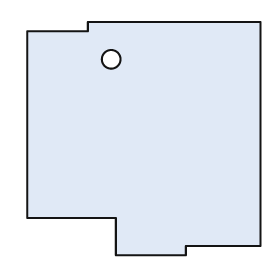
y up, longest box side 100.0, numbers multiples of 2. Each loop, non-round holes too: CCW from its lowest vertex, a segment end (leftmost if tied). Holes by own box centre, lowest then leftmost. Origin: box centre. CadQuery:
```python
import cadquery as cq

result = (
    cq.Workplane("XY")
    .moveTo(-12.0, -50.0)
    .lineTo(18.0, -50.0)
    .lineTo(18.0, -46.0)
    .lineTo(50.0, -46.0)
    .lineTo(50.0, 50.0)
    .lineTo(-24.0, 50.0)
    .lineTo(-24.0, 46.0)
    .lineTo(-50.0, 46.0)
    .lineTo(-50.0, -34.0)
    .lineTo(-12.0, -34.0)
    .close()
    .moveTo(-14.0, 34.0)
    .circle(4.0)
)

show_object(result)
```